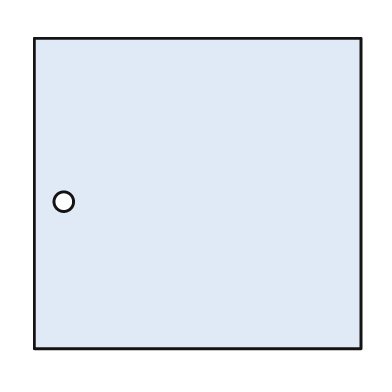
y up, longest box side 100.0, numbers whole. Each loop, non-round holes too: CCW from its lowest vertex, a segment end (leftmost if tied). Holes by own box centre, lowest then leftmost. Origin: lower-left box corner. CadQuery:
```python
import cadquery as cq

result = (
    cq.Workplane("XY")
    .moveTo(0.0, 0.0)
    .lineTo(100.0, 0.0)
    .lineTo(100.0, 95.0)
    .lineTo(0.0, 95.0)
    .close()
    .moveTo(9.0, 45.0)
    .circle(3.0)
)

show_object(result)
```